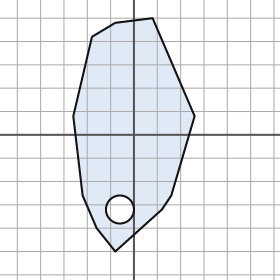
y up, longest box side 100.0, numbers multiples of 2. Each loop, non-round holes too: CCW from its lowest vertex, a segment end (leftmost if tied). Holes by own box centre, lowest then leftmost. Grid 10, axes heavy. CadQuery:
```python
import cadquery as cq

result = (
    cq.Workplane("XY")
    .moveTo(-8.0, -50.0)
    .lineTo(12.0, -32.0)
    .lineTo(16.0, -26.0)
    .lineTo(26.0, 8.0)
    .lineTo(8.0, 50.0)
    .lineTo(-8.0, 48.0)
    .lineTo(-18.0, 42.0)
    .lineTo(-26.0, 8.0)
    .lineTo(-22.0, -26.0)
    .lineTo(-16.0, -40.0)
    .close()
    .moveTo(-6.0, -32.0)
    .circle(6.0)
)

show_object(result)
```